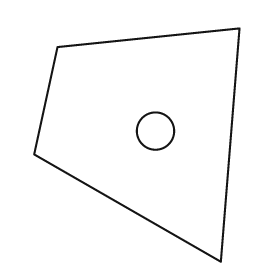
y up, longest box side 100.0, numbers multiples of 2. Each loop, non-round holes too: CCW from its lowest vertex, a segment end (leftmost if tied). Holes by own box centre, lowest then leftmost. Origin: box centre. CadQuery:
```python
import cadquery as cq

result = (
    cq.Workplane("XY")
    .moveTo(36.0, -50.0)
    .lineTo(44.0, 50.0)
    .lineTo(-34.0, 42.0)
    .lineTo(-44.0, -4.0)
    .close()
    .moveTo(8.0, 6.0)
    .circle(8.0)
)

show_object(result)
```